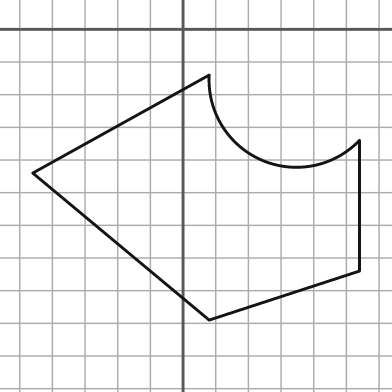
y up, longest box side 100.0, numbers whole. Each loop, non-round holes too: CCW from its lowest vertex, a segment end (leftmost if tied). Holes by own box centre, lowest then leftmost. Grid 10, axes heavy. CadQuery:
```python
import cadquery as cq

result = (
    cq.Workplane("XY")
    .moveTo(8.0, -89.0)
    .lineTo(54.0, -74.0)
    .lineTo(54.0, -34.0)
    .threePointArc((24.0, -40.0), (8.0, -14.0))
    .lineTo(-46.0, -44.0)
    .close()
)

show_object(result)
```